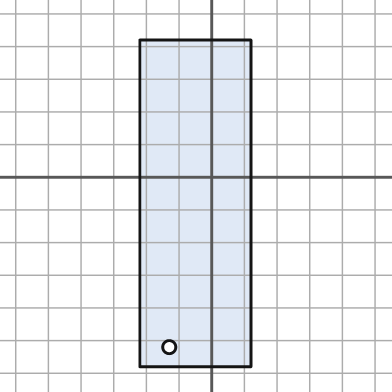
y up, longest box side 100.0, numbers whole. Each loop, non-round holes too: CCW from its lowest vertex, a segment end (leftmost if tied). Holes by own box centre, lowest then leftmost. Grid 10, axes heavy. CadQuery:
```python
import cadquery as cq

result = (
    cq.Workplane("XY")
    .moveTo(-22.0, -58.0)
    .lineTo(12.0, -58.0)
    .lineTo(12.0, 42.0)
    .lineTo(-22.0, 42.0)
    .close()
    .moveTo(-13.0, -52.0)
    .circle(2.0)
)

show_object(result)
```